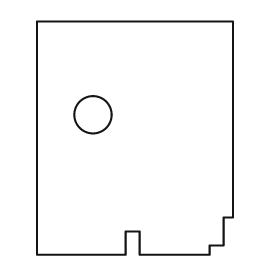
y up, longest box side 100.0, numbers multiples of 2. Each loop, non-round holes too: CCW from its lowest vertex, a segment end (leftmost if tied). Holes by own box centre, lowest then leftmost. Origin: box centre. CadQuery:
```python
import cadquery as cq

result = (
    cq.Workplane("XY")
    .moveTo(-42.0, -50.0)
    .lineTo(-4.0, -50.0)
    .lineTo(-4.0, -40.0)
    .lineTo(2.0, -40.0)
    .lineTo(2.0, -50.0)
    .lineTo(32.0, -50.0)
    .lineTo(32.0, -46.0)
    .lineTo(38.0, -46.0)
    .lineTo(38.0, -34.0)
    .lineTo(42.0, -34.0)
    .lineTo(42.0, 50.0)
    .lineTo(-42.0, 50.0)
    .close()
    .moveTo(-18.0, 10.0)
    .circle(8.0)
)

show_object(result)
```